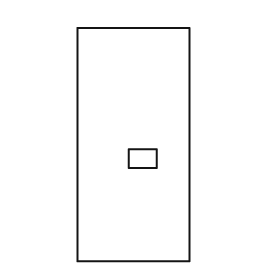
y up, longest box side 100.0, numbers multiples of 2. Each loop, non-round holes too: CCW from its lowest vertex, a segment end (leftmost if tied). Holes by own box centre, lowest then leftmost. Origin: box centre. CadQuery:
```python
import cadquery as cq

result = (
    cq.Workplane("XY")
    .moveTo(-24.0, -50.0)
    .lineTo(24.0, -50.0)
    .lineTo(24.0, 50.0)
    .lineTo(-24.0, 50.0)
    .close()
    .moveTo(-2.0, -10.0)
    .lineTo(10.0, -10.0)
    .lineTo(10.0, -2.0)
    .lineTo(-2.0, -2.0)
    .close()
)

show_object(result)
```